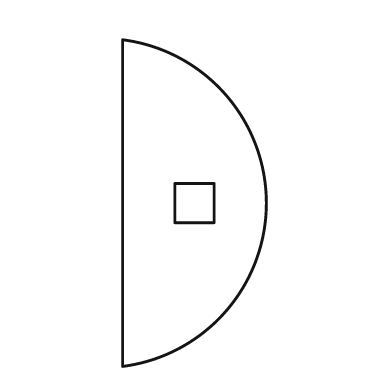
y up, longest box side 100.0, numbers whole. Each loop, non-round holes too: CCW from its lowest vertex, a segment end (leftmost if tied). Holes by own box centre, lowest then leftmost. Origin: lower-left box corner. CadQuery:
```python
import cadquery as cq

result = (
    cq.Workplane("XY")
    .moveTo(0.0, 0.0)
    .threePointArc((44.0, 50.0), (0.0, 100.0))
    .close()
    .moveTo(16.0, 44.0)
    .lineTo(28.0, 44.0)
    .lineTo(28.0, 56.0)
    .lineTo(16.0, 56.0)
    .close()
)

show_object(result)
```